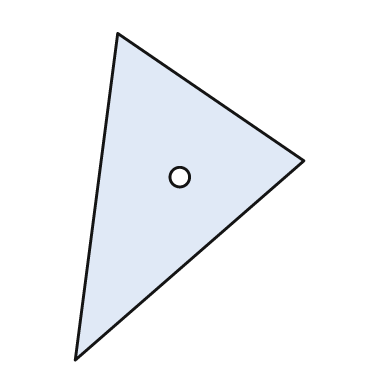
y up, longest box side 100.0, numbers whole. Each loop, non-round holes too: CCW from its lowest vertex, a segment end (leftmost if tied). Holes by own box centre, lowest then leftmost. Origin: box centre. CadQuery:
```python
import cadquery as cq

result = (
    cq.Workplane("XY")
    .moveTo(-35.0, -50.0)
    .lineTo(35.0, 11.0)
    .lineTo(-22.0, 50.0)
    .close()
    .moveTo(-3.0, 6.0)
    .circle(3.0)
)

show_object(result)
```